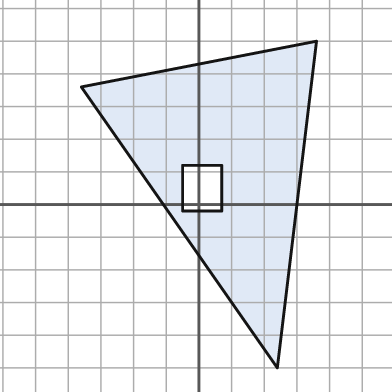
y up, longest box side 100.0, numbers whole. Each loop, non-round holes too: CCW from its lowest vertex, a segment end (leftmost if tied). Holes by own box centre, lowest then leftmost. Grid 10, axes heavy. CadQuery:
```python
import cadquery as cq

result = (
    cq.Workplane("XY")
    .moveTo(24.0, -50.0)
    .lineTo(36.0, 50.0)
    .lineTo(-36.0, 36.0)
    .close()
    .moveTo(-5.0, -2.0)
    .lineTo(7.0, -2.0)
    .lineTo(7.0, 12.0)
    .lineTo(-5.0, 12.0)
    .close()
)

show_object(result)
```